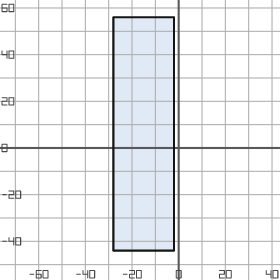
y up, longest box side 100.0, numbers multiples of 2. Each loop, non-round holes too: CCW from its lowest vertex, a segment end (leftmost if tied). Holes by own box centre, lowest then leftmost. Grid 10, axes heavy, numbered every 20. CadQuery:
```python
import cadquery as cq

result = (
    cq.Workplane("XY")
    .moveTo(-28.0, -44.0)
    .lineTo(-2.0, -44.0)
    .lineTo(-2.0, 56.0)
    .lineTo(-28.0, 56.0)
    .close()
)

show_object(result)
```